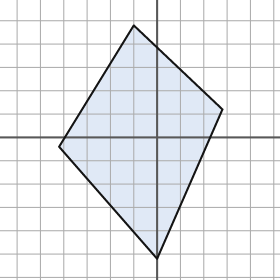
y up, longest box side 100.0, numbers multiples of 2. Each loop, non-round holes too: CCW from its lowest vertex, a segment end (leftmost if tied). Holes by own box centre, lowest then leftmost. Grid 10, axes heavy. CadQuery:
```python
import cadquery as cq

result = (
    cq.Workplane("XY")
    .moveTo(0.0, -52.0)
    .lineTo(28.0, 12.0)
    .lineTo(-10.0, 48.0)
    .lineTo(-42.0, -4.0)
    .close()
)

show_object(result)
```